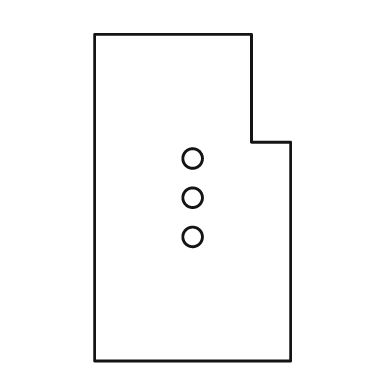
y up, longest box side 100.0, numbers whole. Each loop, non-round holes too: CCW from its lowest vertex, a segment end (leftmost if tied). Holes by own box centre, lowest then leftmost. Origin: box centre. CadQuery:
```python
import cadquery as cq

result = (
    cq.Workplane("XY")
    .moveTo(-30.0, -50.0)
    .lineTo(30.0, -50.0)
    .lineTo(30.0, 17.0)
    .lineTo(18.0, 17.0)
    .lineTo(18.0, 50.0)
    .lineTo(-30.0, 50.0)
    .close()
    .moveTo(0.0, -12.0)
    .circle(3.0)
    .moveTo(0.0, 0.0)
    .circle(3.0)
    .moveTo(0.0, 12.0)
    .circle(3.0)
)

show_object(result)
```